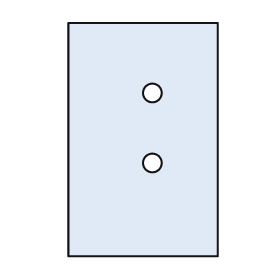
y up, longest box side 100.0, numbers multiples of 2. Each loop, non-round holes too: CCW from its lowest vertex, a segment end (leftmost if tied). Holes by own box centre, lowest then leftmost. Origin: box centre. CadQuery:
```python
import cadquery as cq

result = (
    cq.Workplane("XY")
    .moveTo(-32.0, -50.0)
    .lineTo(32.0, -50.0)
    .lineTo(32.0, 50.0)
    .lineTo(-32.0, 50.0)
    .close()
    .moveTo(4.0, -10.0)
    .circle(4.0)
    .moveTo(4.0, 20.0)
    .circle(4.0)
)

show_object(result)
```